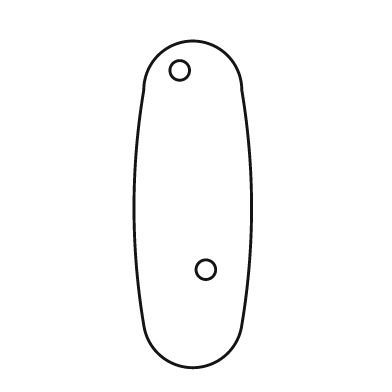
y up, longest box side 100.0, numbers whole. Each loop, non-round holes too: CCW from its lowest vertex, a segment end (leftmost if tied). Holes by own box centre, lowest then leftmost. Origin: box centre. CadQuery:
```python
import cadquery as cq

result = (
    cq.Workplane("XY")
    .moveTo(-15.0, -37.0)
    .threePointArc((0.0, -50.0), (15.0, -37.0))
    .threePointArc((18.0, -1.0), (15.0, 35.0))
    .threePointArc((0.0, 50.0), (-15.0, 35.0))
    .threePointArc((-18.0, -1.0), (-15.0, -37.0))
    .close()
    .moveTo(4.0, -20.0)
    .circle(3.0)
    .moveTo(-4.0, 41.0)
    .circle(3.0)
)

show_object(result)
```